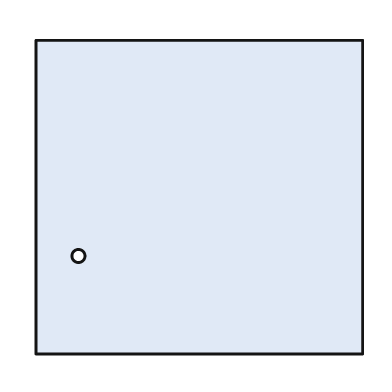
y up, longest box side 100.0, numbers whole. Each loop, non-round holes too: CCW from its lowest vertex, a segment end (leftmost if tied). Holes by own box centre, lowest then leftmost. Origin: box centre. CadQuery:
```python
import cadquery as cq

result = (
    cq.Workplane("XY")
    .moveTo(-50.0, -48.0)
    .lineTo(50.0, -48.0)
    .lineTo(50.0, 48.0)
    .lineTo(-50.0, 48.0)
    .close()
    .moveTo(-37.0, -18.0)
    .circle(2.0)
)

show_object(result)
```